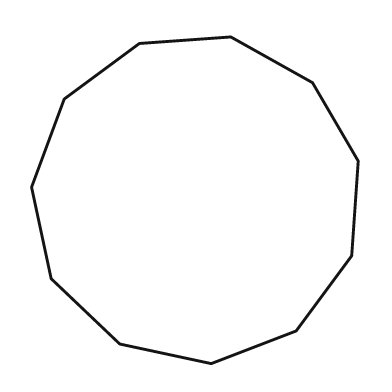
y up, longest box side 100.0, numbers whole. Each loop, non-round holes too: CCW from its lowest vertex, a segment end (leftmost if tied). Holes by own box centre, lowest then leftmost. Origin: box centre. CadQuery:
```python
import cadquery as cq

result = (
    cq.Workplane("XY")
    .moveTo(5.0, -50.0)
    .lineTo(31.0, -40.0)
    .lineTo(48.0, -17.0)
    .lineTo(50.0, 12.0)
    .lineTo(36.0, 36.0)
    .lineTo(11.0, 50.0)
    .lineTo(-17.0, 48.0)
    .lineTo(-40.0, 31.0)
    .lineTo(-50.0, 4.0)
    .lineTo(-44.0, -24.0)
    .lineTo(-23.0, -44.0)
    .close()
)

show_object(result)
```